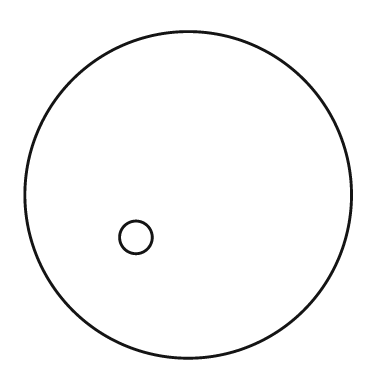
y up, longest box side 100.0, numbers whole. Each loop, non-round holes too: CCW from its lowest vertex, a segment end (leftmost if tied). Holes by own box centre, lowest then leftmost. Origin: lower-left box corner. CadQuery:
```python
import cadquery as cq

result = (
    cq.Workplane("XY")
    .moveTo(50.0, 50.0)
    .circle(50.0)
    .moveTo(34.0, 37.0)
    .circle(5.0)
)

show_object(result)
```